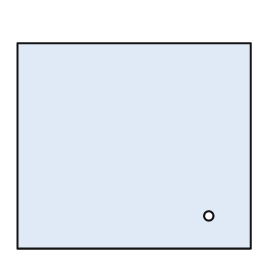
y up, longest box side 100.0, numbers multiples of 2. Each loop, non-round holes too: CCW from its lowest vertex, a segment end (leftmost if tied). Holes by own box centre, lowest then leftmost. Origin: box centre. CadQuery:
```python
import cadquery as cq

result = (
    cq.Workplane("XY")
    .moveTo(-50.0, -44.0)
    .lineTo(50.0, -44.0)
    .lineTo(50.0, 44.0)
    .lineTo(-50.0, 44.0)
    .close()
    .moveTo(32.0, -30.0)
    .circle(2.0)
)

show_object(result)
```